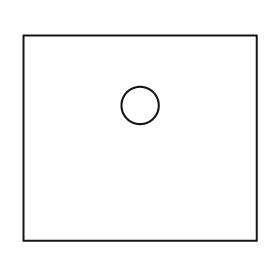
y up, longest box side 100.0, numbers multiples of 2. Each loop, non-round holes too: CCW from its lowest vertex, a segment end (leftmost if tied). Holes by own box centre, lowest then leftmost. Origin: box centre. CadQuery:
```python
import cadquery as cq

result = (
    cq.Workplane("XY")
    .moveTo(-50.0, -44.0)
    .lineTo(50.0, -44.0)
    .lineTo(50.0, 44.0)
    .lineTo(-50.0, 44.0)
    .close()
    .moveTo(0.0, 14.0)
    .circle(8.0)
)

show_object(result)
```